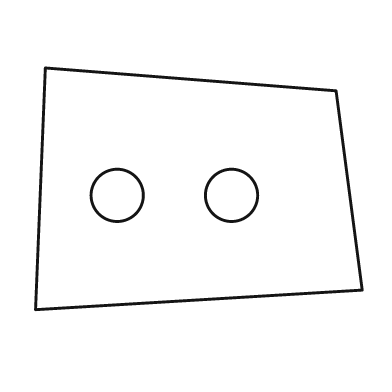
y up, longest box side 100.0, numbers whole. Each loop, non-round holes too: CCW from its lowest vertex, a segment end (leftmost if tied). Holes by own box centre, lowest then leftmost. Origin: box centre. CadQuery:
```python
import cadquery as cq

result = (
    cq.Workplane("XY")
    .moveTo(-50.0, -37.0)
    .lineTo(50.0, -31.0)
    .lineTo(42.0, 30.0)
    .lineTo(-47.0, 37.0)
    .close()
    .moveTo(-25.0, -2.0)
    .circle(8.0)
    .moveTo(10.0, -2.0)
    .circle(8.0)
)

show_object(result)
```